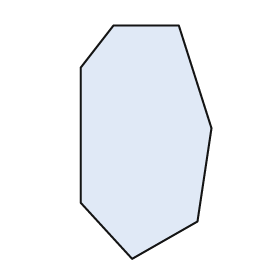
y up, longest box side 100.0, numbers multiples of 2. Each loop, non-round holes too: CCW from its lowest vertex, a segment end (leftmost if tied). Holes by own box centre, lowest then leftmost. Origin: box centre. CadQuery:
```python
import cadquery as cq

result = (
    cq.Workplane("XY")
    .moveTo(-6.0, -50.0)
    .lineTo(22.0, -34.0)
    .lineTo(28.0, 6.0)
    .lineTo(14.0, 50.0)
    .lineTo(-14.0, 50.0)
    .lineTo(-28.0, 32.0)
    .lineTo(-28.0, -26.0)
    .close()
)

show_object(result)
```